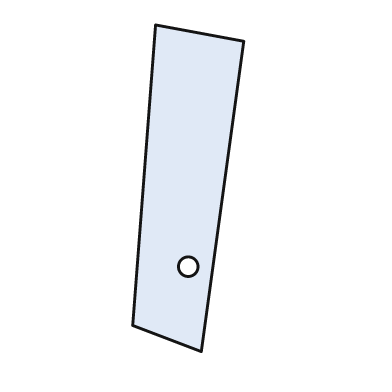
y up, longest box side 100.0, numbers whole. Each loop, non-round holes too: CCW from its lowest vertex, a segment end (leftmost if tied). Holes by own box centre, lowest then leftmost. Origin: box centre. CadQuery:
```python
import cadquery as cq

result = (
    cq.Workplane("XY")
    .moveTo(4.0, -50.0)
    .lineTo(17.0, 45.0)
    .lineTo(-10.0, 50.0)
    .lineTo(-17.0, -42.0)
    .close()
    .moveTo(0.0, -24.0)
    .circle(3.0)
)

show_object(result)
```